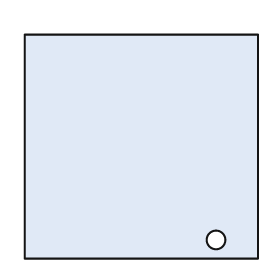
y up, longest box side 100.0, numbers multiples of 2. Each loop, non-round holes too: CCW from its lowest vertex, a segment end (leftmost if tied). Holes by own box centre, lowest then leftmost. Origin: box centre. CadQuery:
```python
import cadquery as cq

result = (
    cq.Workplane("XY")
    .moveTo(-50.0, -48.0)
    .lineTo(50.0, -48.0)
    .lineTo(50.0, 48.0)
    .lineTo(-50.0, 48.0)
    .close()
    .moveTo(32.0, -40.0)
    .circle(4.0)
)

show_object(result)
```